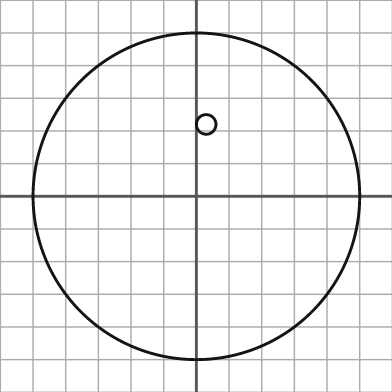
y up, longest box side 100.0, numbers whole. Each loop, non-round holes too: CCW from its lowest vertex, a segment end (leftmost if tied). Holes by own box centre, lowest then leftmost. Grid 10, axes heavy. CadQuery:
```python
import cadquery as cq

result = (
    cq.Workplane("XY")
    .moveTo(0.0, 0.0)
    .circle(50.0)
    .moveTo(3.0, 22.0)
    .circle(3.0)
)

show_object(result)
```